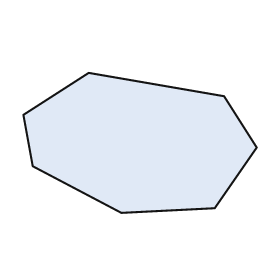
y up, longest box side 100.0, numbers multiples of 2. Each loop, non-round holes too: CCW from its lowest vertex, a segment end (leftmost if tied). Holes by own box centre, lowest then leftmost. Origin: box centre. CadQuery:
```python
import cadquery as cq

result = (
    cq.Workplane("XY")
    .moveTo(-8.0, -30.0)
    .lineTo(32.0, -28.0)
    .lineTo(50.0, -2.0)
    .lineTo(36.0, 20.0)
    .lineTo(-22.0, 30.0)
    .lineTo(-50.0, 12.0)
    .lineTo(-46.0, -10.0)
    .close()
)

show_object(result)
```